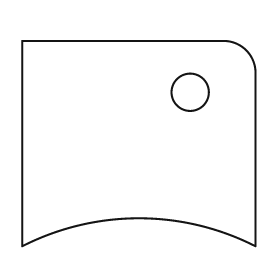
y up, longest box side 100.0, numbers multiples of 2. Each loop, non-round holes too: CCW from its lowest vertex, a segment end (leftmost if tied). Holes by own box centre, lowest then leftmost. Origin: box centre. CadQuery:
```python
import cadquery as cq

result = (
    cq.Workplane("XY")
    .moveTo(-50.0, -44.0)
    .threePointArc((0.0, -32.0), (50.0, -44.0))
    .lineTo(50.0, 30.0)
    .threePointArc((46.0, 40.0), (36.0, 44.0))
    .lineTo(-50.0, 44.0)
    .close()
    .moveTo(22.0, 22.0)
    .circle(8.0)
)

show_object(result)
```